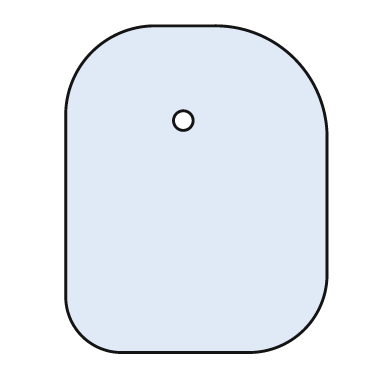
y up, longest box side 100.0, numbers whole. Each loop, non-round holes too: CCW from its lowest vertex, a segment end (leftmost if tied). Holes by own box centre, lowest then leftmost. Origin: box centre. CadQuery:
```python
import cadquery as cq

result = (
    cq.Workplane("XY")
    .moveTo(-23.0, -50.0)
    .lineTo(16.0, -50.0)
    .threePointArc((33.0, -43.0), (40.0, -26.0))
    .lineTo(40.0, 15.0)
    .threePointArc((30.0, 40.0), (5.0, 50.0))
    .lineTo(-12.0, 50.0)
    .threePointArc((-32.0, 42.0), (-40.0, 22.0))
    .lineTo(-40.0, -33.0)
    .threePointArc((-35.0, -45.0), (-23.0, -50.0))
    .close()
    .moveTo(-4.0, 21.0)
    .circle(3.0)
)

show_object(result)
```